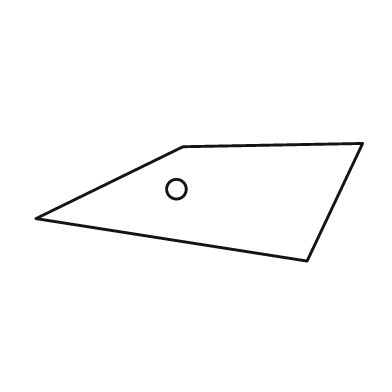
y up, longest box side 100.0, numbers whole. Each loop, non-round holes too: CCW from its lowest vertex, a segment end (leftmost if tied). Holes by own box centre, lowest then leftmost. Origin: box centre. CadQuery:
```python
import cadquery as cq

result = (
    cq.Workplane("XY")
    .moveTo(33.0, -18.0)
    .lineTo(50.0, 18.0)
    .lineTo(-5.0, 17.0)
    .lineTo(-50.0, -5.0)
    .close()
    .moveTo(-7.0, 4.0)
    .circle(3.0)
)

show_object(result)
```